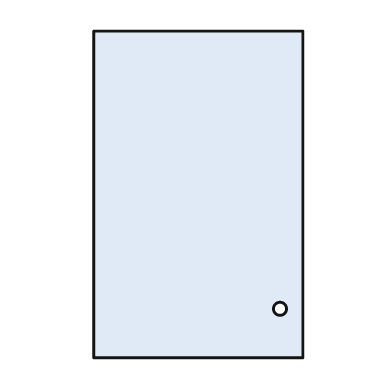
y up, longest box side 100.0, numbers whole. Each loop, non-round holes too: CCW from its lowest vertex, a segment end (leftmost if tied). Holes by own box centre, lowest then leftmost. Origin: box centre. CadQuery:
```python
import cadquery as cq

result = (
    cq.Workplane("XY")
    .moveTo(-32.0, -50.0)
    .lineTo(32.0, -50.0)
    .lineTo(32.0, 50.0)
    .lineTo(-32.0, 50.0)
    .close()
    .moveTo(25.0, -35.0)
    .circle(2.0)
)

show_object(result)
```